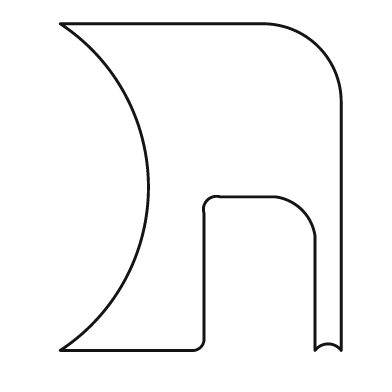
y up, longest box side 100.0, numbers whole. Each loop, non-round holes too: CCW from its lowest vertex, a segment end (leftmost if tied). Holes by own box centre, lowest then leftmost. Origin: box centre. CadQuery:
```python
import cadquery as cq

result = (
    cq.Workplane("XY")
    .moveTo(-43.0, -50.0)
    .lineTo(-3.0, -50.0)
    .threePointArc((0.0, -49.0), (1.0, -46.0))
    .lineTo(1.0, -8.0)
    .threePointArc((2.0, -4.0), (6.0, -3.0))
    .lineTo(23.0, -3.0)
    .threePointArc((31.0, -7.0), (35.0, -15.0))
    .lineTo(35.0, -50.0)
    .threePointArc((39.0, -48.0), (43.0, -50.0))
    .lineTo(43.0, 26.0)
    .threePointArc((36.0, 43.0), (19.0, 50.0))
    .lineTo(-43.0, 50.0)
    .threePointArc((-16.0, 0.0), (-43.0, -50.0))
    .close()
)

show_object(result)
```